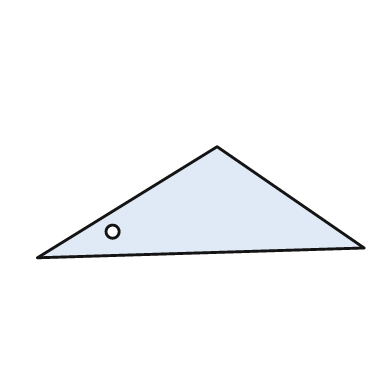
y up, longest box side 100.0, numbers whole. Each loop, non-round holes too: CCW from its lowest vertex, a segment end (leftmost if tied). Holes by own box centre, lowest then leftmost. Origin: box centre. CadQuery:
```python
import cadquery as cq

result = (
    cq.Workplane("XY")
    .moveTo(-50.0, -17.0)
    .lineTo(50.0, -14.0)
    .lineTo(5.0, 17.0)
    .close()
    .moveTo(-27.0, -9.0)
    .circle(2.0)
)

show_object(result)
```